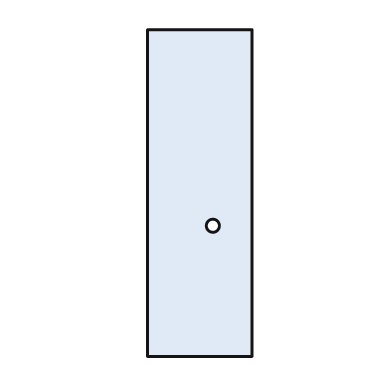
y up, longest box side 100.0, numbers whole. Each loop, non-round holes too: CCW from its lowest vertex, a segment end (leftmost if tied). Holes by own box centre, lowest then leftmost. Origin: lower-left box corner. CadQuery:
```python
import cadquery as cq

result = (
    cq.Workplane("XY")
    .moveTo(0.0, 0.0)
    .lineTo(32.0, 0.0)
    .lineTo(32.0, 100.0)
    .lineTo(0.0, 100.0)
    .close()
    .moveTo(20.0, 40.0)
    .circle(2.0)
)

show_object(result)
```